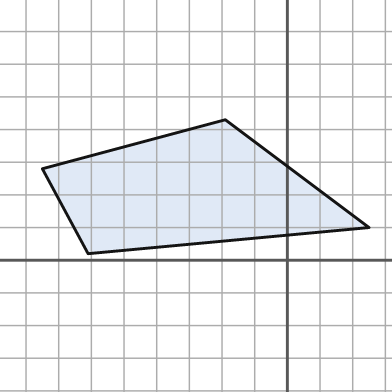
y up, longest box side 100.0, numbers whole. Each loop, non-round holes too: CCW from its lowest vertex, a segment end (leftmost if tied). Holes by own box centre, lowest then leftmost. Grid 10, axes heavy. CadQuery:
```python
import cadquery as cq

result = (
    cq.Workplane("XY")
    .moveTo(-61.0, 2.0)
    .lineTo(25.0, 10.0)
    .lineTo(-19.0, 43.0)
    .lineTo(-75.0, 28.0)
    .close()
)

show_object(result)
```